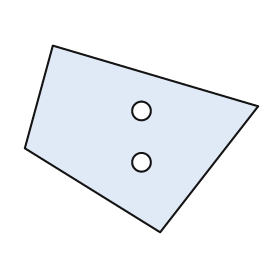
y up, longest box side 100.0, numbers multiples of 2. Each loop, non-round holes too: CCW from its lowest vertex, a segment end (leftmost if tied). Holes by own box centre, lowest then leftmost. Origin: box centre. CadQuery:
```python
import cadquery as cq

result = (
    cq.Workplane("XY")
    .moveTo(8.0, -40.0)
    .lineTo(50.0, 14.0)
    .lineTo(-38.0, 40.0)
    .lineTo(-50.0, -4.0)
    .close()
    .moveTo(0.0, -10.0)
    .circle(4.0)
    .moveTo(0.0, 12.0)
    .circle(4.0)
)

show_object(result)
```